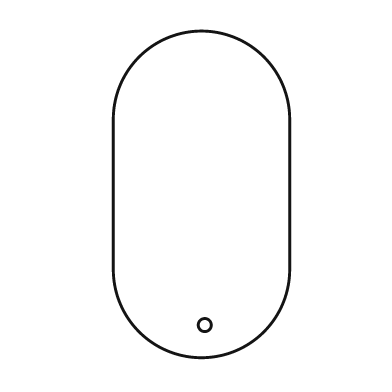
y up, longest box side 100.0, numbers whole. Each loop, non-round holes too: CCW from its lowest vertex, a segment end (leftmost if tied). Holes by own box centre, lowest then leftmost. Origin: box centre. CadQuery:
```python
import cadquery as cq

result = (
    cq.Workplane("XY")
    .moveTo(-27.0, -23.0)
    .threePointArc((0.0, -50.0), (27.0, -23.0))
    .lineTo(27.0, 23.0)
    .threePointArc((0.0, 50.0), (-27.0, 23.0))
    .close()
    .moveTo(1.0, -40.0)
    .circle(2.0)
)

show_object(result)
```